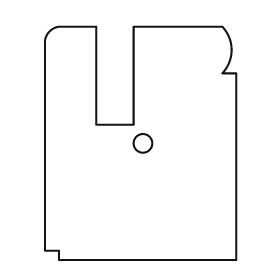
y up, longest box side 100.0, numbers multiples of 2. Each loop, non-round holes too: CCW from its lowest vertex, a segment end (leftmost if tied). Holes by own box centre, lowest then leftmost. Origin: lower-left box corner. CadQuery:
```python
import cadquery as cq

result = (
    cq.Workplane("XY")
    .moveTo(6.0, 0.0)
    .lineTo(82.0, 0.0)
    .lineTo(82.0, 80.0)
    .lineTo(76.0, 80.0)
    .threePointArc((80.0, 90.0), (76.0, 100.0))
    .lineTo(38.0, 100.0)
    .lineTo(38.0, 58.0)
    .lineTo(22.0, 58.0)
    .lineTo(22.0, 100.0)
    .lineTo(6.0, 100.0)
    .threePointArc((2.0, 98.0), (0.0, 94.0))
    .lineTo(0.0, 4.0)
    .lineTo(6.0, 4.0)
    .close()
    .moveTo(42.0, 50.0)
    .circle(4.0)
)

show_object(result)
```